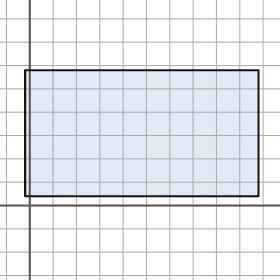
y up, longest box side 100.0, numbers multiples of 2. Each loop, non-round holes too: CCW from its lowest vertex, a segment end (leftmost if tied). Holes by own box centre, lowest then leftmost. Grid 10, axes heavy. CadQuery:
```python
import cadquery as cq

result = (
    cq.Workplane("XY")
    .moveTo(-2.0, 4.0)
    .lineTo(98.0, 4.0)
    .lineTo(98.0, 58.0)
    .lineTo(-2.0, 58.0)
    .close()
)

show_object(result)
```